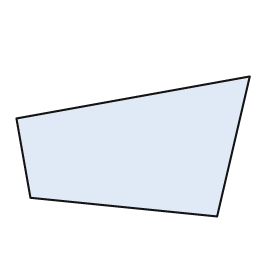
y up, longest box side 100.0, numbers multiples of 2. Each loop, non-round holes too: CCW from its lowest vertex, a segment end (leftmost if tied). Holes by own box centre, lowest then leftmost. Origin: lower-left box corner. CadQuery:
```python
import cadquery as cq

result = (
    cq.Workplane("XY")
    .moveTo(86.0, 0.0)
    .lineTo(100.0, 60.0)
    .lineTo(0.0, 42.0)
    .lineTo(6.0, 8.0)
    .close()
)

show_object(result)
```